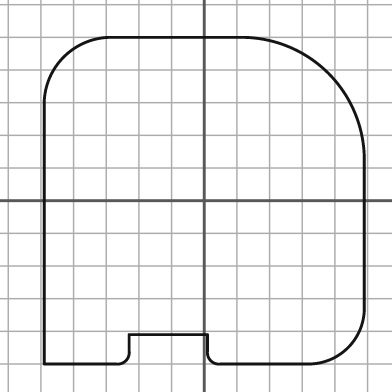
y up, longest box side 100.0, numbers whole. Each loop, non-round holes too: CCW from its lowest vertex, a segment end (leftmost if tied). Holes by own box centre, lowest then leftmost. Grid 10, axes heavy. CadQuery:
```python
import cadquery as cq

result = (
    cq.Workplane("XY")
    .moveTo(-49.0, -50.0)
    .lineTo(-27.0, -50.0)
    .threePointArc((-24.0, -49.0), (-23.0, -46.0))
    .lineTo(-23.0, -41.0)
    .lineTo(1.0, -41.0)
    .lineTo(1.0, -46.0)
    .threePointArc((2.0, -49.0), (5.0, -50.0))
    .lineTo(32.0, -50.0)
    .threePointArc((44.0, -45.0), (49.0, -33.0))
    .lineTo(49.0, 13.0)
    .threePointArc((38.0, 39.0), (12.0, 50.0))
    .lineTo(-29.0, 50.0)
    .threePointArc((-43.0, 44.0), (-49.0, 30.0))
    .close()
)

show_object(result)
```